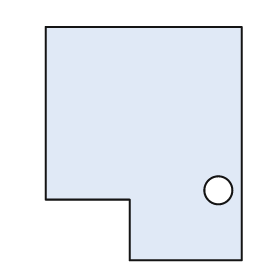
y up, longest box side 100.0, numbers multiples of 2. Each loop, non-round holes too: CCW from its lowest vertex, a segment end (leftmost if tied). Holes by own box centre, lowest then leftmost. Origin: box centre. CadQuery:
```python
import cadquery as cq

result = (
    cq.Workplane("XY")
    .moveTo(-6.0, -50.0)
    .lineTo(42.0, -50.0)
    .lineTo(42.0, 50.0)
    .lineTo(-42.0, 50.0)
    .lineTo(-42.0, -24.0)
    .lineTo(-6.0, -24.0)
    .close()
    .moveTo(32.0, -20.0)
    .circle(6.0)
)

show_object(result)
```